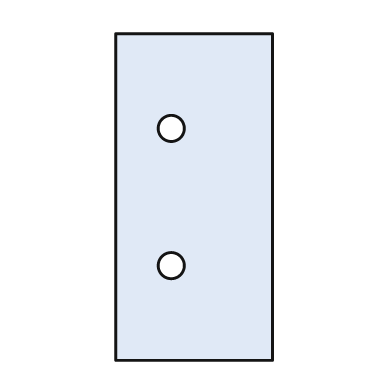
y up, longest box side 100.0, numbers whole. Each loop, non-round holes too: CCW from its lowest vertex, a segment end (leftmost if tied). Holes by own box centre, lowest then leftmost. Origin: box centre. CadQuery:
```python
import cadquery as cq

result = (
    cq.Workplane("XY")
    .moveTo(-24.0, -50.0)
    .lineTo(24.0, -50.0)
    .lineTo(24.0, 50.0)
    .lineTo(-24.0, 50.0)
    .close()
    .moveTo(-7.0, -21.0)
    .circle(4.0)
    .moveTo(-7.0, 21.0)
    .circle(4.0)
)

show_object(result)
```